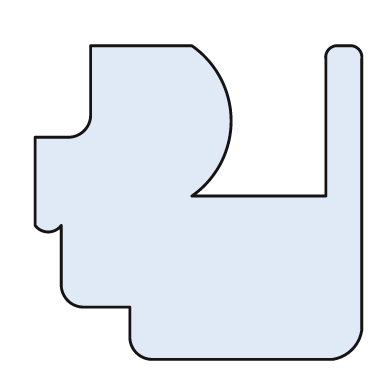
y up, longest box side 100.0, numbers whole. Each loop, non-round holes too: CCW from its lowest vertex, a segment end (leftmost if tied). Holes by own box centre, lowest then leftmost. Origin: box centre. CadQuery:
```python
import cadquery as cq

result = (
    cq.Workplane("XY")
    .moveTo(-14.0, -48.0)
    .lineTo(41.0, -48.0)
    .threePointArc((47.0, -45.0), (50.0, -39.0))
    .lineTo(50.0, 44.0)
    .threePointArc((49.0, 47.0), (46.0, 48.0))
    .lineTo(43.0, 48.0)
    .threePointArc((40.0, 47.0), (39.0, 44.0))
    .lineTo(39.0, 2.0)
    .lineTo(-2.0, 2.0)
    .threePointArc((10.0, 25.0), (-2.0, 48.0))
    .lineTo(-33.0, 48.0)
    .lineTo(-33.0, 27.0)
    .threePointArc((-35.0, 22.0), (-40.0, 20.0))
    .lineTo(-50.0, 20.0)
    .lineTo(-50.0, -7.0)
    .threePointArc((-46.0, -9.0), (-42.0, -7.0))
    .lineTo(-42.0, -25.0)
    .threePointArc((-40.0, -30.0), (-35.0, -32.0))
    .lineTo(-21.0, -32.0)
    .lineTo(-21.0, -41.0)
    .threePointArc((-19.0, -46.0), (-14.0, -48.0))
    .close()
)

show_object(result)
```